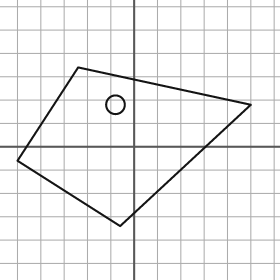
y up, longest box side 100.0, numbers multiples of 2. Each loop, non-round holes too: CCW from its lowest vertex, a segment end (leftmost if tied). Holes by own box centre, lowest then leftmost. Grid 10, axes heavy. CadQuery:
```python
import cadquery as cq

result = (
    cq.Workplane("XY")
    .moveTo(-6.0, -34.0)
    .lineTo(50.0, 18.0)
    .lineTo(-24.0, 34.0)
    .lineTo(-50.0, -6.0)
    .close()
    .moveTo(-8.0, 18.0)
    .circle(4.0)
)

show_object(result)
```